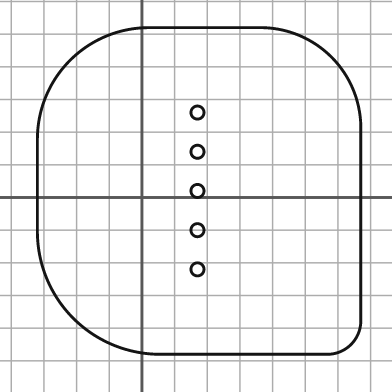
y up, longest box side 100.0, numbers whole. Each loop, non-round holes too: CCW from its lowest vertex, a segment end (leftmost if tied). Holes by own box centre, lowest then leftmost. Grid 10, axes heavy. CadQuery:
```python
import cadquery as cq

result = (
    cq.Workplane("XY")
    .moveTo(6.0, -48.0)
    .lineTo(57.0, -48.0)
    .threePointArc((64.0, -45.0), (67.0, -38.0))
    .lineTo(67.0, 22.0)
    .threePointArc((58.0, 43.0), (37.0, 52.0))
    .lineTo(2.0, 52.0)
    .threePointArc((-22.0, 42.0), (-32.0, 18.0))
    .lineTo(-32.0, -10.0)
    .threePointArc((-21.0, -37.0), (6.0, -48.0))
    .close()
    .moveTo(17.0, -22.0)
    .circle(2.0)
    .moveTo(17.0, -10.0)
    .circle(2.0)
    .moveTo(17.0, 2.0)
    .circle(2.0)
    .moveTo(17.0, 14.0)
    .circle(2.0)
    .moveTo(17.0, 26.0)
    .circle(2.0)
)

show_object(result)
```